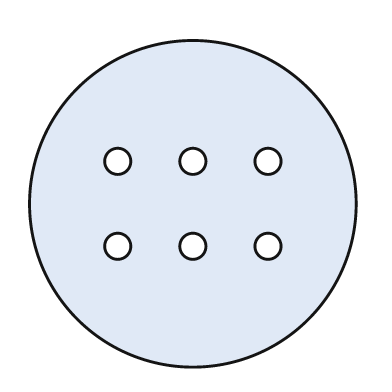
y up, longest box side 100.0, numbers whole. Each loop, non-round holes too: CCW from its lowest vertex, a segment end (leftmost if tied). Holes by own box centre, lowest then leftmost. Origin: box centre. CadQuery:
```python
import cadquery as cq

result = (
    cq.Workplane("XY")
    .moveTo(0.0, 0.0)
    .circle(50.0)
    .moveTo(-23.0, -13.0)
    .circle(4.0)
    .moveTo(0.0, -13.0)
    .circle(4.0)
    .moveTo(23.0, -13.0)
    .circle(4.0)
    .moveTo(-23.0, 13.0)
    .circle(4.0)
    .moveTo(0.0, 13.0)
    .circle(4.0)
    .moveTo(23.0, 13.0)
    .circle(4.0)
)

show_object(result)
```